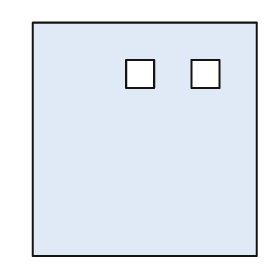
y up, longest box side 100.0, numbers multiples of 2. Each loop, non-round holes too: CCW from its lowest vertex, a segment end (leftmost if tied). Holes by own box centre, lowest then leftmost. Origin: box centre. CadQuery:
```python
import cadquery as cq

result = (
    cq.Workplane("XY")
    .moveTo(-48.0, -50.0)
    .lineTo(48.0, -50.0)
    .lineTo(48.0, 50.0)
    .lineTo(-48.0, 50.0)
    .close()
    .moveTo(-8.0, 22.0)
    .lineTo(4.0, 22.0)
    .lineTo(4.0, 34.0)
    .lineTo(-8.0, 34.0)
    .close()
    .moveTo(20.0, 22.0)
    .lineTo(32.0, 22.0)
    .lineTo(32.0, 34.0)
    .lineTo(20.0, 34.0)
    .close()
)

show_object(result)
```